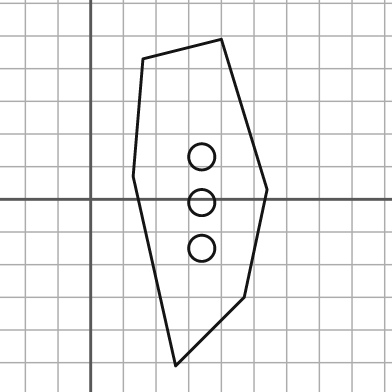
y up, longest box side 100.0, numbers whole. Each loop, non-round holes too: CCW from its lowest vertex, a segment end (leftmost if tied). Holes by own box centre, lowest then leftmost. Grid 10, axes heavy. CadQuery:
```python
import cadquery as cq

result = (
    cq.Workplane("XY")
    .moveTo(26.0, -51.0)
    .lineTo(47.0, -30.0)
    .lineTo(54.0, 3.0)
    .lineTo(40.0, 49.0)
    .lineTo(16.0, 43.0)
    .lineTo(13.0, 7.0)
    .close()
    .moveTo(34.0, -15.0)
    .circle(4.0)
    .moveTo(34.0, -1.0)
    .circle(4.0)
    .moveTo(34.0, 13.0)
    .circle(4.0)
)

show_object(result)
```